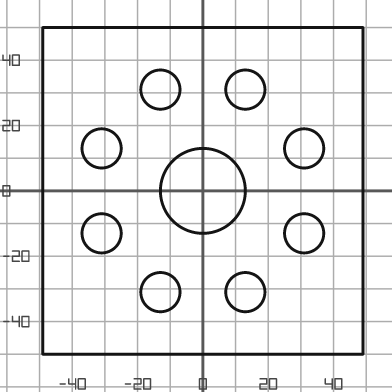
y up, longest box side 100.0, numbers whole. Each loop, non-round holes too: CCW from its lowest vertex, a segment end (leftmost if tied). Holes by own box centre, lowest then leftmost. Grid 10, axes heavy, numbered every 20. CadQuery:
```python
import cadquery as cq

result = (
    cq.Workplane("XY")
    .moveTo(-49.0, -50.0)
    .lineTo(49.0, -50.0)
    .lineTo(49.0, 50.0)
    .lineTo(-49.0, 50.0)
    .close()
    .moveTo(-13.0, -31.0)
    .circle(6.0)
    .moveTo(13.0, -31.0)
    .circle(6.0)
    .moveTo(-31.0, -13.0)
    .circle(6.0)
    .moveTo(31.0, -13.0)
    .circle(6.0)
    .moveTo(0.0, 0.0)
    .circle(13.0)
    .moveTo(-31.0, 13.0)
    .circle(6.0)
    .moveTo(31.0, 13.0)
    .circle(6.0)
    .moveTo(-13.0, 31.0)
    .circle(6.0)
    .moveTo(13.0, 31.0)
    .circle(6.0)
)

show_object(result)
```